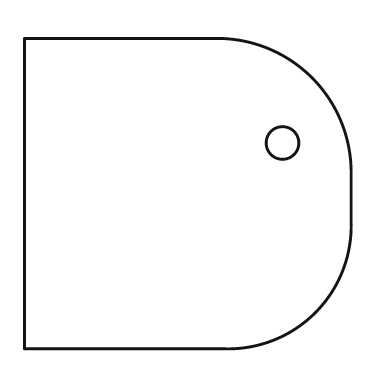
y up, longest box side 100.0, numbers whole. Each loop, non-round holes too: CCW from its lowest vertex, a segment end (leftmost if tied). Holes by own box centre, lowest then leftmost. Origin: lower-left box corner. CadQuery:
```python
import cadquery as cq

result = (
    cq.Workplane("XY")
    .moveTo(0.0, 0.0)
    .lineTo(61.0, 0.0)
    .threePointArc((89.0, 11.0), (100.0, 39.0))
    .lineTo(100.0, 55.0)
    .threePointArc((88.0, 83.0), (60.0, 95.0))
    .lineTo(0.0, 95.0)
    .close()
    .moveTo(79.0, 63.0)
    .circle(5.0)
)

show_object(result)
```